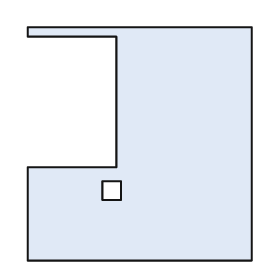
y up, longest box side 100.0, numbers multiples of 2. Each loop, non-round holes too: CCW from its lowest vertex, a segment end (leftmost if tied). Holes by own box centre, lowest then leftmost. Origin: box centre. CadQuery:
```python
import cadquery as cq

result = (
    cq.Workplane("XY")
    .moveTo(-48.0, -50.0)
    .lineTo(48.0, -50.0)
    .lineTo(48.0, 50.0)
    .lineTo(-48.0, 50.0)
    .lineTo(-48.0, 46.0)
    .lineTo(-10.0, 46.0)
    .lineTo(-10.0, -10.0)
    .lineTo(-48.0, -10.0)
    .close()
    .moveTo(-16.0, -24.0)
    .lineTo(-8.0, -24.0)
    .lineTo(-8.0, -16.0)
    .lineTo(-16.0, -16.0)
    .close()
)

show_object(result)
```